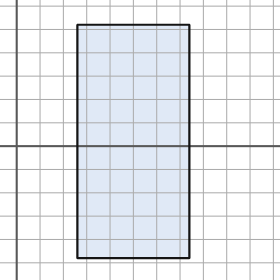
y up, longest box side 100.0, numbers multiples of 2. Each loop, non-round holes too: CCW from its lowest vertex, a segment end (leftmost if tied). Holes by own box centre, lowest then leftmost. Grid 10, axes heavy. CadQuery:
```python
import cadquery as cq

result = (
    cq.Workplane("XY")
    .moveTo(26.0, -48.0)
    .lineTo(74.0, -48.0)
    .lineTo(74.0, 52.0)
    .lineTo(26.0, 52.0)
    .close()
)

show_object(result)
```